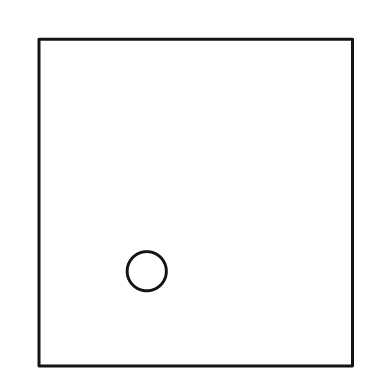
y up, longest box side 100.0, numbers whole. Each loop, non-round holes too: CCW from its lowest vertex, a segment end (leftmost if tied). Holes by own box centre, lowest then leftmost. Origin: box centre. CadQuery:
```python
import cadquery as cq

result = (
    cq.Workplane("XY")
    .moveTo(-48.0, -50.0)
    .lineTo(48.0, -50.0)
    .lineTo(48.0, 50.0)
    .lineTo(-48.0, 50.0)
    .close()
    .moveTo(-15.0, -21.0)
    .circle(6.0)
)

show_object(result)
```